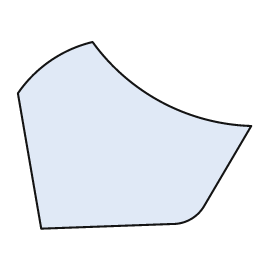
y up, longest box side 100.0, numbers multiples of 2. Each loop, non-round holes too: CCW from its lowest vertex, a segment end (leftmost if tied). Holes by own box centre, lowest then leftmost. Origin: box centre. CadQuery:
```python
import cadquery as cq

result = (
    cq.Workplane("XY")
    .moveTo(-40.0, -40.0)
    .lineTo(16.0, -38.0)
    .threePointArc((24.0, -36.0), (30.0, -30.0))
    .lineTo(50.0, 4.0)
    .threePointArc((12.0, 14.0), (-18.0, 40.0))
    .threePointArc((-36.0, 32.0), (-50.0, 18.0))
    .close()
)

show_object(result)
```